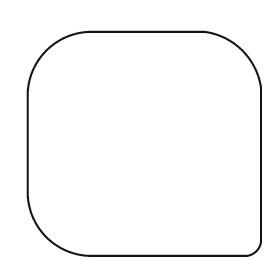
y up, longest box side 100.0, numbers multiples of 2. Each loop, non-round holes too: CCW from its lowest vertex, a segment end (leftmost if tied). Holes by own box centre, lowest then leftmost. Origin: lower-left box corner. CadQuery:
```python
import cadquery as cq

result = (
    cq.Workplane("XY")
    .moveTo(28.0, 0.0)
    .lineTo(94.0, 0.0)
    .threePointArc((98.0, 2.0), (100.0, 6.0))
    .lineTo(100.0, 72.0)
    .threePointArc((92.0, 88.0), (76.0, 96.0))
    .lineTo(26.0, 96.0)
    .threePointArc((8.0, 88.0), (0.0, 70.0))
    .lineTo(0.0, 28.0)
    .threePointArc((8.0, 8.0), (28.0, 0.0))
    .close()
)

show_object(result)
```